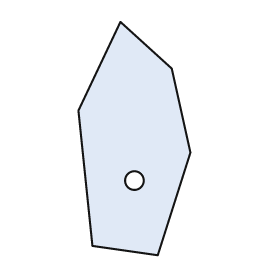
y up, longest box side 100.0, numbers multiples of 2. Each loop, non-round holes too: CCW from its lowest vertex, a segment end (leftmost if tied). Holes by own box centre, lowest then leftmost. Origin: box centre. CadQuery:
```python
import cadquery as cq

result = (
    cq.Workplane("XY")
    .moveTo(10.0, -50.0)
    .lineTo(24.0, -6.0)
    .lineTo(16.0, 30.0)
    .lineTo(-6.0, 50.0)
    .lineTo(-24.0, 12.0)
    .lineTo(-18.0, -46.0)
    .close()
    .moveTo(0.0, -18.0)
    .circle(4.0)
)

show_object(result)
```